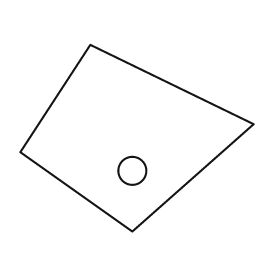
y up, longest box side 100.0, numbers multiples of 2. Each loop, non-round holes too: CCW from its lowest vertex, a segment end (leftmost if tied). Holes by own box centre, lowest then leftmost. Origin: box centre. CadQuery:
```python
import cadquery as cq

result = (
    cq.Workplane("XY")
    .moveTo(-2.0, -40.0)
    .lineTo(50.0, 6.0)
    .lineTo(-20.0, 40.0)
    .lineTo(-50.0, -6.0)
    .close()
    .moveTo(-2.0, -14.0)
    .circle(6.0)
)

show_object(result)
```